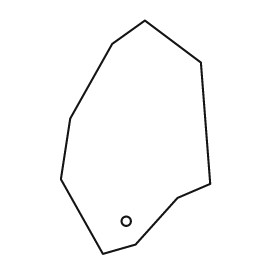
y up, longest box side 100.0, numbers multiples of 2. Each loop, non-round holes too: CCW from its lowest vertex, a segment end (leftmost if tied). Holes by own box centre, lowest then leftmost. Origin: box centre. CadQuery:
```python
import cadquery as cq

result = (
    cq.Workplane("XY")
    .moveTo(-14.0, -50.0)
    .lineTo(0.0, -46.0)
    .lineTo(18.0, -26.0)
    .lineTo(32.0, -20.0)
    .lineTo(28.0, 32.0)
    .lineTo(4.0, 50.0)
    .lineTo(-10.0, 40.0)
    .lineTo(-28.0, 8.0)
    .lineTo(-32.0, -18.0)
    .close()
    .moveTo(-4.0, -36.0)
    .circle(2.0)
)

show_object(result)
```